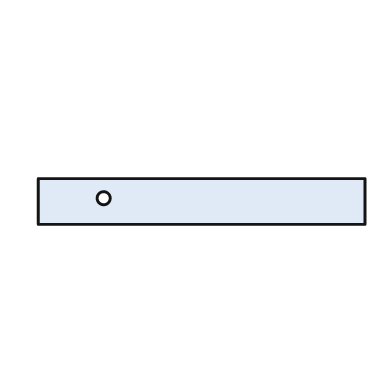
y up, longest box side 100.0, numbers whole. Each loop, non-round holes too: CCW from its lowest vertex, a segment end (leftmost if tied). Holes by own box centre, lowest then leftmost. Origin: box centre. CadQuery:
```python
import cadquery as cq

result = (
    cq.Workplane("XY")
    .moveTo(-50.0, -7.0)
    .lineTo(50.0, -7.0)
    .lineTo(50.0, 7.0)
    .lineTo(-50.0, 7.0)
    .close()
    .moveTo(-30.0, 1.0)
    .circle(2.0)
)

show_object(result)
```